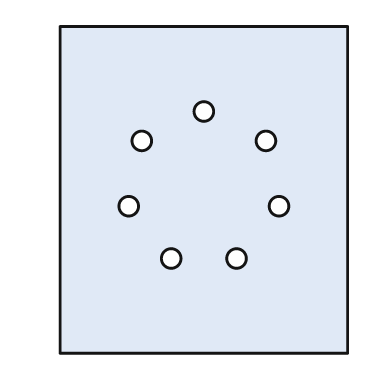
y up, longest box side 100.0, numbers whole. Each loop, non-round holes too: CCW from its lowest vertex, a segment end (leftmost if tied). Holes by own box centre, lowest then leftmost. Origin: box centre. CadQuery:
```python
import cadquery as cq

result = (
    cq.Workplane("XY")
    .moveTo(-44.0, -50.0)
    .lineTo(44.0, -50.0)
    .lineTo(44.0, 50.0)
    .lineTo(-44.0, 50.0)
    .close()
    .moveTo(-10.0, -21.0)
    .circle(3.0)
    .moveTo(10.0, -21.0)
    .circle(3.0)
    .moveTo(-23.0, -5.0)
    .circle(3.0)
    .moveTo(23.0, -5.0)
    .circle(3.0)
    .moveTo(-19.0, 15.0)
    .circle(3.0)
    .moveTo(19.0, 15.0)
    .circle(3.0)
    .moveTo(0.0, 24.0)
    .circle(3.0)
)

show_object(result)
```